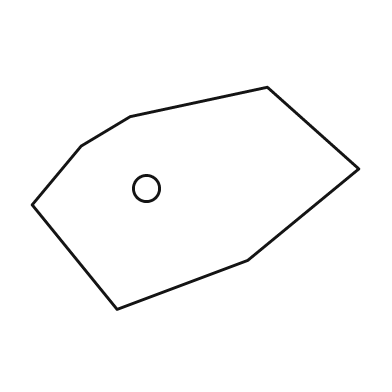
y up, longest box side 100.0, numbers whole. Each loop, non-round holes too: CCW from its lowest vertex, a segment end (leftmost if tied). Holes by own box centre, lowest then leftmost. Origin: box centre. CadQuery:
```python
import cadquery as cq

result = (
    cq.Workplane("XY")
    .moveTo(-24.0, -34.0)
    .lineTo(16.0, -19.0)
    .lineTo(50.0, 9.0)
    .lineTo(22.0, 34.0)
    .lineTo(-20.0, 25.0)
    .lineTo(-35.0, 16.0)
    .lineTo(-50.0, -2.0)
    .close()
    .moveTo(-15.0, 3.0)
    .circle(4.0)
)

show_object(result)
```